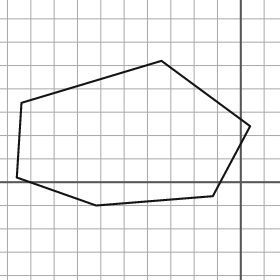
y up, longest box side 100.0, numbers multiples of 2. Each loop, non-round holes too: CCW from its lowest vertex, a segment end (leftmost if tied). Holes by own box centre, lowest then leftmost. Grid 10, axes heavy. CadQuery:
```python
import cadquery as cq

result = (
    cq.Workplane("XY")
    .moveTo(-62.0, -10.0)
    .lineTo(-12.0, -6.0)
    .lineTo(4.0, 24.0)
    .lineTo(-34.0, 52.0)
    .lineTo(-94.0, 34.0)
    .lineTo(-96.0, 2.0)
    .close()
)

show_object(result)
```